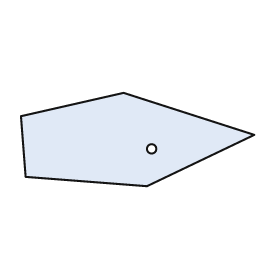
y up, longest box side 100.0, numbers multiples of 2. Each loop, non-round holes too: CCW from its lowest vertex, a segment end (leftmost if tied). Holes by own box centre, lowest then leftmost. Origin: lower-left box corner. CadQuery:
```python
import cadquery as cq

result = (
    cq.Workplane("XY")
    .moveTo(54.0, 0.0)
    .lineTo(100.0, 22.0)
    .lineTo(44.0, 40.0)
    .lineTo(0.0, 30.0)
    .lineTo(2.0, 4.0)
    .close()
    .moveTo(56.0, 16.0)
    .circle(2.0)
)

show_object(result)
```